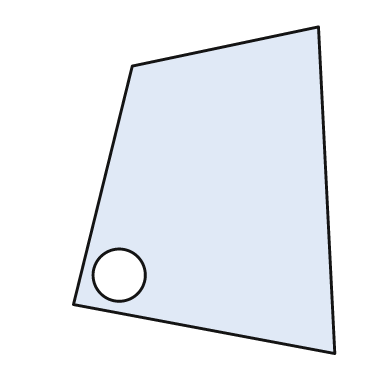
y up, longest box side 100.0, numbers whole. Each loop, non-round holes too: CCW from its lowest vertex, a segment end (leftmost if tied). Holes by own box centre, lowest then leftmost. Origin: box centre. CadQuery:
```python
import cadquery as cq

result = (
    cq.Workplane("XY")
    .moveTo(40.0, -50.0)
    .lineTo(35.0, 50.0)
    .lineTo(-22.0, 38.0)
    .lineTo(-40.0, -35.0)
    .close()
    .moveTo(-26.0, -26.0)
    .circle(8.0)
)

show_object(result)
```